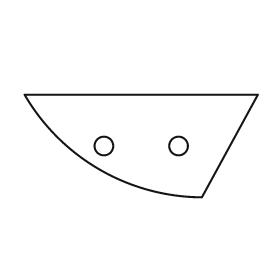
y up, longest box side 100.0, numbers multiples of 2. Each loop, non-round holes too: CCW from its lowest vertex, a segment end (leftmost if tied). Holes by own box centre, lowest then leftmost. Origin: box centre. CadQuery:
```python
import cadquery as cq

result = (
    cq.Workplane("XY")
    .moveTo(26.0, -22.0)
    .lineTo(50.0, 22.0)
    .lineTo(-50.0, 22.0)
    .threePointArc((-18.0, -10.0), (26.0, -22.0))
    .close()
    .moveTo(-16.0, 0.0)
    .circle(4.0)
    .moveTo(16.0, 0.0)
    .circle(4.0)
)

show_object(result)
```